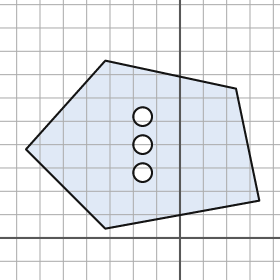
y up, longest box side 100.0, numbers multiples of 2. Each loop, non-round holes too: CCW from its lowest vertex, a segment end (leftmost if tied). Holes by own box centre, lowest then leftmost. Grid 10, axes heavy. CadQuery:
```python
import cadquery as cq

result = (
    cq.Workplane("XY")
    .moveTo(-32.0, 4.0)
    .lineTo(34.0, 16.0)
    .lineTo(24.0, 64.0)
    .lineTo(-32.0, 76.0)
    .lineTo(-66.0, 38.0)
    .close()
    .moveTo(-16.0, 28.0)
    .circle(4.0)
    .moveTo(-16.0, 40.0)
    .circle(4.0)
    .moveTo(-16.0, 52.0)
    .circle(4.0)
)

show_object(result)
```